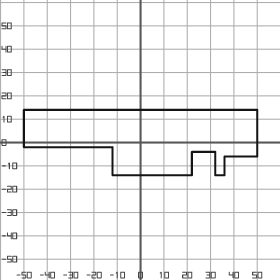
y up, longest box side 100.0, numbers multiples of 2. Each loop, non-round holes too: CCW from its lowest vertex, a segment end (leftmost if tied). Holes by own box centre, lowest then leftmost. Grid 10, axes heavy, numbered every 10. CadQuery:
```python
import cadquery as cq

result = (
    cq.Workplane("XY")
    .moveTo(-12.0, -14.0)
    .lineTo(22.0, -14.0)
    .lineTo(22.0, -4.0)
    .lineTo(32.0, -4.0)
    .lineTo(32.0, -14.0)
    .lineTo(36.0, -14.0)
    .lineTo(36.0, -6.0)
    .lineTo(50.0, -6.0)
    .lineTo(50.0, 14.0)
    .lineTo(-50.0, 14.0)
    .lineTo(-50.0, -2.0)
    .lineTo(-12.0, -2.0)
    .close()
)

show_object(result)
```